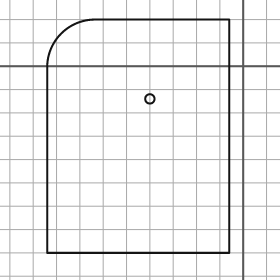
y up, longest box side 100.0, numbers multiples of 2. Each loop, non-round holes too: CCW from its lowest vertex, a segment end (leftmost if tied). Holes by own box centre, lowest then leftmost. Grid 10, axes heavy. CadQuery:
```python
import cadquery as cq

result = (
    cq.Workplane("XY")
    .moveTo(-84.0, -80.0)
    .lineTo(-6.0, -80.0)
    .lineTo(-6.0, 20.0)
    .lineTo(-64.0, 20.0)
    .threePointArc((-78.0, 14.0), (-84.0, 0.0))
    .close()
    .moveTo(-40.0, -14.0)
    .circle(2.0)
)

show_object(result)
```